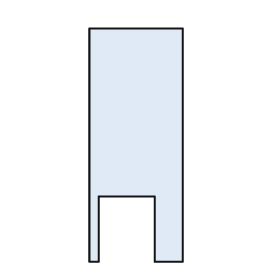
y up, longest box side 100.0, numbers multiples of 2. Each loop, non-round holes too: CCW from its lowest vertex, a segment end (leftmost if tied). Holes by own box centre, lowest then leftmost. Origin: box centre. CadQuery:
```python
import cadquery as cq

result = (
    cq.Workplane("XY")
    .moveTo(-20.0, -50.0)
    .lineTo(-16.0, -50.0)
    .lineTo(-16.0, -22.0)
    .lineTo(8.0, -22.0)
    .lineTo(8.0, -50.0)
    .lineTo(20.0, -50.0)
    .lineTo(20.0, 50.0)
    .lineTo(-20.0, 50.0)
    .close()
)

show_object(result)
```